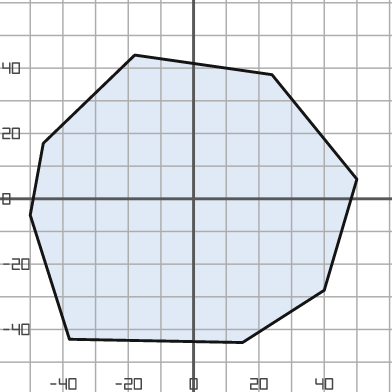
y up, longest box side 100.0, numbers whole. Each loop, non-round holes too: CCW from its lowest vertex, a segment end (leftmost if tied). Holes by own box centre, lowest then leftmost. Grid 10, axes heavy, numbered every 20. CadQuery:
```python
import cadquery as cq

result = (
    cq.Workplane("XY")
    .moveTo(15.0, -44.0)
    .lineTo(40.0, -28.0)
    .lineTo(50.0, 6.0)
    .lineTo(24.0, 38.0)
    .lineTo(-18.0, 44.0)
    .lineTo(-46.0, 17.0)
    .lineTo(-50.0, -5.0)
    .lineTo(-38.0, -43.0)
    .close()
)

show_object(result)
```